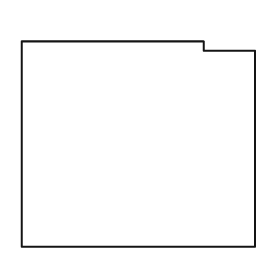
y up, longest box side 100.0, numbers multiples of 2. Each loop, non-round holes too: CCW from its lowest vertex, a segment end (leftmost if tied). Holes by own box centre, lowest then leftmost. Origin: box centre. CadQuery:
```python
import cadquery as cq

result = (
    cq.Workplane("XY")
    .moveTo(-50.0, -44.0)
    .lineTo(50.0, -44.0)
    .lineTo(50.0, 40.0)
    .lineTo(28.0, 40.0)
    .lineTo(28.0, 44.0)
    .lineTo(-50.0, 44.0)
    .close()
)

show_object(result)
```